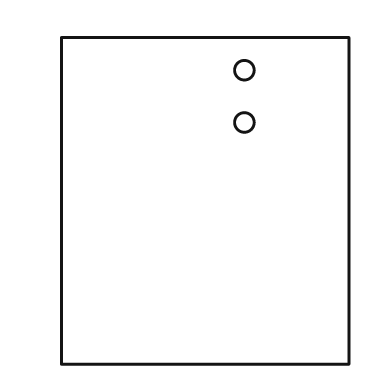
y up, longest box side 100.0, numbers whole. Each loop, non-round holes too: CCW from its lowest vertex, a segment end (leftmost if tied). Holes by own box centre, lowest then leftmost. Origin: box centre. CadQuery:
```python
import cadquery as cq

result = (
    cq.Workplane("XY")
    .moveTo(-44.0, -50.0)
    .lineTo(44.0, -50.0)
    .lineTo(44.0, 50.0)
    .lineTo(-44.0, 50.0)
    .close()
    .moveTo(12.0, 24.0)
    .circle(3.0)
    .moveTo(12.0, 40.0)
    .circle(3.0)
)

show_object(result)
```